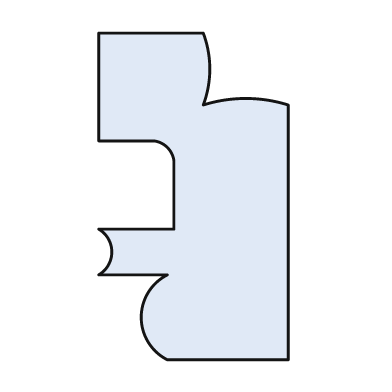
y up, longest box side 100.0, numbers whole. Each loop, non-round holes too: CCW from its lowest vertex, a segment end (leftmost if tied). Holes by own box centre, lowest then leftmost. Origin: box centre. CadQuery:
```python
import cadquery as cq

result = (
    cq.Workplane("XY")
    .moveTo(-8.0, -50.0)
    .lineTo(29.0, -50.0)
    .lineTo(29.0, 28.0)
    .threePointArc((16.0, 30.0), (3.0, 28.0))
    .threePointArc((5.0, 39.0), (3.0, 50.0))
    .lineTo(-29.0, 50.0)
    .lineTo(-29.0, 17.0)
    .lineTo(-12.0, 17.0)
    .threePointArc((-8.0, 15.0), (-6.0, 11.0))
    .lineTo(-6.0, -10.0)
    .lineTo(-29.0, -10.0)
    .threePointArc((-25.0, -17.0), (-29.0, -24.0))
    .lineTo(-8.0, -24.0)
    .threePointArc((-16.0, -37.0), (-8.0, -50.0))
    .close()
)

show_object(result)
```